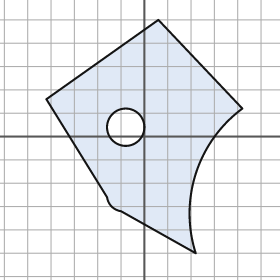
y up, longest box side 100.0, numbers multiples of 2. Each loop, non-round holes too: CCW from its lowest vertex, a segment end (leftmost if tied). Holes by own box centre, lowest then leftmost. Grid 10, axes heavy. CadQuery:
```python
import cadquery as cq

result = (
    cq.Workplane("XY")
    .moveTo(22.0, -50.0)
    .threePointArc((22.0, -16.0), (42.0, 12.0))
    .lineTo(6.0, 50.0)
    .lineTo(-42.0, 16.0)
    .lineTo(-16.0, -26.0)
    .threePointArc((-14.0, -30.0), (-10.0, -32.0))
    .close()
    .moveTo(-8.0, 4.0)
    .circle(8.0)
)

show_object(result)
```